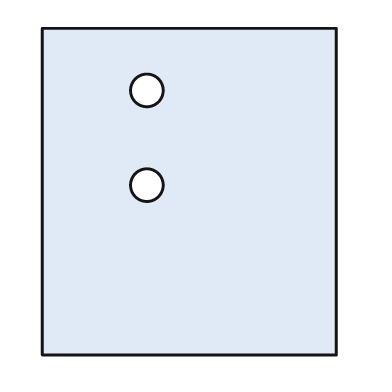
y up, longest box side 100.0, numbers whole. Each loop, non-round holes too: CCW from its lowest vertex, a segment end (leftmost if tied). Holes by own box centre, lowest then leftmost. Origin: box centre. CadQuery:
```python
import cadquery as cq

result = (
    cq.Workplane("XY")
    .moveTo(-45.0, -50.0)
    .lineTo(45.0, -50.0)
    .lineTo(45.0, 50.0)
    .lineTo(-45.0, 50.0)
    .close()
    .moveTo(-13.0, 2.0)
    .circle(5.0)
    .moveTo(-13.0, 31.0)
    .circle(5.0)
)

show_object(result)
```